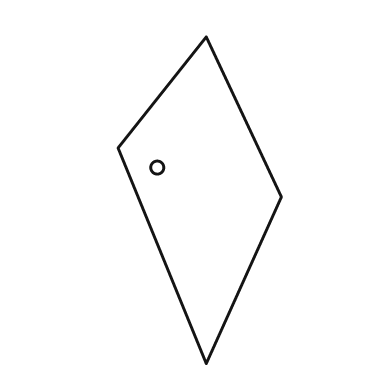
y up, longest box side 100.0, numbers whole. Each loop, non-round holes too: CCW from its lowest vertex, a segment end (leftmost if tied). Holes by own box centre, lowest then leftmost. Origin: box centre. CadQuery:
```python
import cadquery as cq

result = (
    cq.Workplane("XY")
    .moveTo(2.0, -50.0)
    .lineTo(25.0, 1.0)
    .lineTo(2.0, 50.0)
    .lineTo(-25.0, 16.0)
    .close()
    .moveTo(-13.0, 10.0)
    .circle(2.0)
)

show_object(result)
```